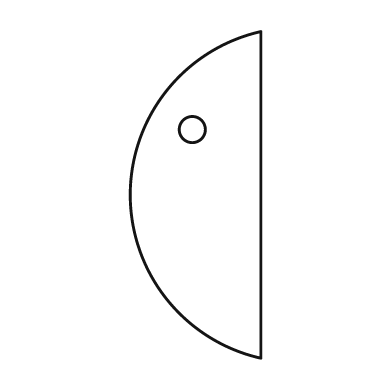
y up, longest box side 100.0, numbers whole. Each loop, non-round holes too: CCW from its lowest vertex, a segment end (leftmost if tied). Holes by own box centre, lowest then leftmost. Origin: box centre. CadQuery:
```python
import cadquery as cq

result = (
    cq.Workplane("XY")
    .moveTo(20.0, -50.0)
    .lineTo(20.0, 50.0)
    .threePointArc((-20.0, 0.0), (20.0, -50.0))
    .close()
    .moveTo(-1.0, 20.0)
    .circle(4.0)
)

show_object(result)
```